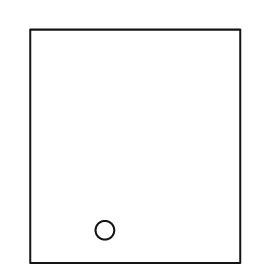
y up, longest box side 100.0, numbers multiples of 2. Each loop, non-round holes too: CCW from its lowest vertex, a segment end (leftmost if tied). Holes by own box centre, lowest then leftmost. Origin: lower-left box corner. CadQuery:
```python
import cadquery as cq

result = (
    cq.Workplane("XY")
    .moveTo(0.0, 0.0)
    .lineTo(90.0, 0.0)
    .lineTo(90.0, 100.0)
    .lineTo(0.0, 100.0)
    .close()
    .moveTo(32.0, 14.0)
    .circle(4.0)
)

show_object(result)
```